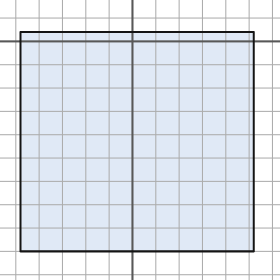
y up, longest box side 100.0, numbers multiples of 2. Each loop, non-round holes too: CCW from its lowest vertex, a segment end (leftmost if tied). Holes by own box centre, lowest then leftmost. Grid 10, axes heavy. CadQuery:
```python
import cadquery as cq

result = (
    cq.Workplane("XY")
    .moveTo(-48.0, -90.0)
    .lineTo(52.0, -90.0)
    .lineTo(52.0, 4.0)
    .lineTo(-48.0, 4.0)
    .close()
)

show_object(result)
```